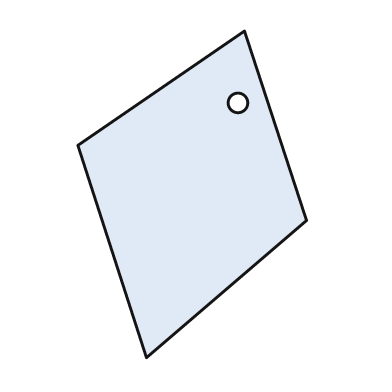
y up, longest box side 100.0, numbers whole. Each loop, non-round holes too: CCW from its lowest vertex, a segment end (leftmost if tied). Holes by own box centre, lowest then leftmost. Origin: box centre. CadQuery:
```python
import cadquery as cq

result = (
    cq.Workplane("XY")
    .moveTo(-14.0, -50.0)
    .lineTo(35.0, -8.0)
    .lineTo(16.0, 50.0)
    .lineTo(-35.0, 15.0)
    .close()
    .moveTo(14.0, 28.0)
    .circle(3.0)
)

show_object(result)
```